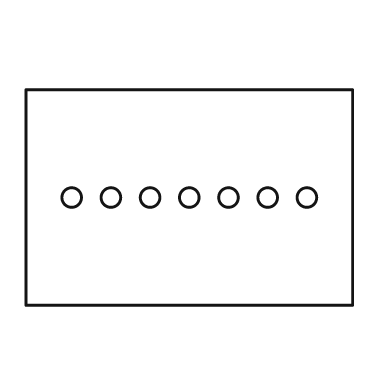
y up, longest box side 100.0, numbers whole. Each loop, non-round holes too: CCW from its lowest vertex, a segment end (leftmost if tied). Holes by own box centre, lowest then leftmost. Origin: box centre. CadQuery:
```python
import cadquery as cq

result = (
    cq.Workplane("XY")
    .moveTo(-50.0, -33.0)
    .lineTo(50.0, -33.0)
    .lineTo(50.0, 33.0)
    .lineTo(-50.0, 33.0)
    .close()
    .moveTo(-36.0, 0.0)
    .circle(3.0)
    .moveTo(-24.0, 0.0)
    .circle(3.0)
    .moveTo(-12.0, 0.0)
    .circle(3.0)
    .moveTo(0.0, 0.0)
    .circle(3.0)
    .moveTo(12.0, 0.0)
    .circle(3.0)
    .moveTo(24.0, 0.0)
    .circle(3.0)
    .moveTo(36.0, 0.0)
    .circle(3.0)
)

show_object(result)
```